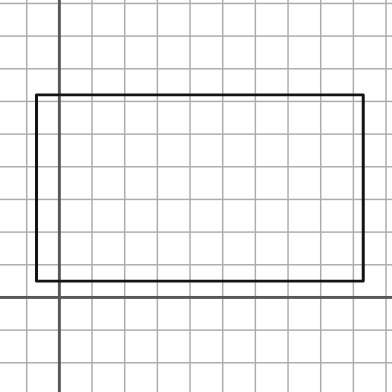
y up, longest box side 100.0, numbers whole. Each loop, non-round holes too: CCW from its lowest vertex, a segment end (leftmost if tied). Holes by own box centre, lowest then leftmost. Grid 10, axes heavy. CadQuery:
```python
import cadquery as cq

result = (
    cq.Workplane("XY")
    .moveTo(-7.0, 5.0)
    .lineTo(93.0, 5.0)
    .lineTo(93.0, 62.0)
    .lineTo(-7.0, 62.0)
    .close()
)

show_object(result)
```